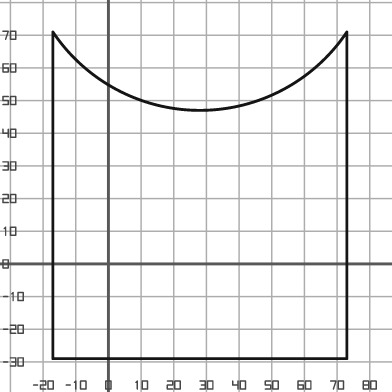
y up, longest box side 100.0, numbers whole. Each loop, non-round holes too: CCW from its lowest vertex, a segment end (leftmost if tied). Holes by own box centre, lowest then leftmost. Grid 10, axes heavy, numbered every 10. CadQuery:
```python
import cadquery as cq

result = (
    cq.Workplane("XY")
    .moveTo(-17.0, -29.0)
    .lineTo(73.0, -29.0)
    .lineTo(73.0, 71.0)
    .threePointArc((28.0, 47.0), (-17.0, 71.0))
    .close()
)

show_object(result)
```